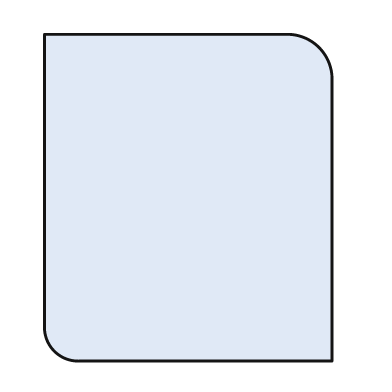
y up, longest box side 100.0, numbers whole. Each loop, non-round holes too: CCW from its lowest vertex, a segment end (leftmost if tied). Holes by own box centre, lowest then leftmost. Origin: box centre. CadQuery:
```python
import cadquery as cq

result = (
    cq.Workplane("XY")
    .moveTo(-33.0, -50.0)
    .lineTo(44.0, -50.0)
    .lineTo(44.0, 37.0)
    .threePointArc((40.0, 46.0), (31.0, 50.0))
    .lineTo(-44.0, 50.0)
    .lineTo(-44.0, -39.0)
    .threePointArc((-41.0, -47.0), (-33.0, -50.0))
    .close()
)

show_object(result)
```